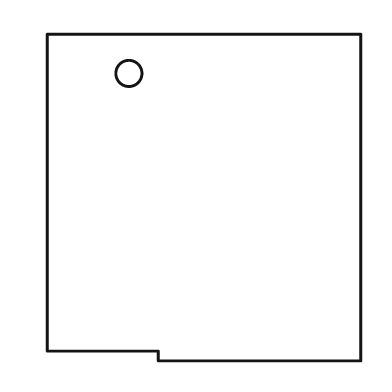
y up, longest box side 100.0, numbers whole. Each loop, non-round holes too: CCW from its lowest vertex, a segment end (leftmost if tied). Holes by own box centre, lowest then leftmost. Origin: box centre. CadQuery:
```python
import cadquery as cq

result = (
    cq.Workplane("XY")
    .moveTo(-14.0, -50.0)
    .lineTo(48.0, -50.0)
    .lineTo(48.0, 50.0)
    .lineTo(-48.0, 50.0)
    .lineTo(-48.0, -47.0)
    .lineTo(-14.0, -47.0)
    .close()
    .moveTo(-23.0, 38.0)
    .circle(4.0)
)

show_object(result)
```